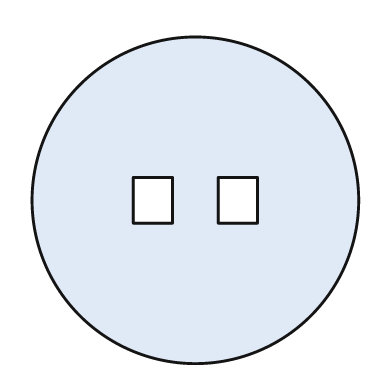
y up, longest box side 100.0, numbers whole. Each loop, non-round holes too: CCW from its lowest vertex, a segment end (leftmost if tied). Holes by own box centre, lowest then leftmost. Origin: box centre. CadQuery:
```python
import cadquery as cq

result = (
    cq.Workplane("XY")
    .moveTo(0.0, 0.0)
    .circle(50.0)
    .moveTo(-19.0, -7.0)
    .lineTo(-7.0, -7.0)
    .lineTo(-7.0, 7.0)
    .lineTo(-19.0, 7.0)
    .close()
    .moveTo(7.0, -7.0)
    .lineTo(19.0, -7.0)
    .lineTo(19.0, 7.0)
    .lineTo(7.0, 7.0)
    .close()
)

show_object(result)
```